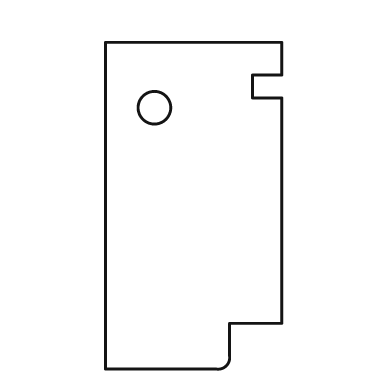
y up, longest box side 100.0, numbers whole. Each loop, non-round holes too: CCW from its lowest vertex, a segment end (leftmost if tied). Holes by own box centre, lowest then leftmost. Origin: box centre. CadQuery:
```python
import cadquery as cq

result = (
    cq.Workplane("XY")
    .moveTo(-27.0, -50.0)
    .lineTo(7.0, -50.0)
    .threePointArc((10.0, -49.0), (11.0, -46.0))
    .lineTo(11.0, -36.0)
    .lineTo(27.0, -36.0)
    .lineTo(27.0, 33.0)
    .lineTo(18.0, 33.0)
    .lineTo(18.0, 40.0)
    .lineTo(27.0, 40.0)
    .lineTo(27.0, 50.0)
    .lineTo(-27.0, 50.0)
    .close()
    .moveTo(-12.0, 30.0)
    .circle(5.0)
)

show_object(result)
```